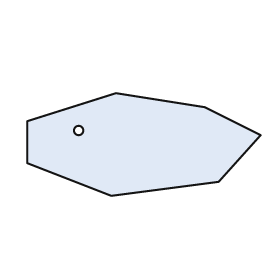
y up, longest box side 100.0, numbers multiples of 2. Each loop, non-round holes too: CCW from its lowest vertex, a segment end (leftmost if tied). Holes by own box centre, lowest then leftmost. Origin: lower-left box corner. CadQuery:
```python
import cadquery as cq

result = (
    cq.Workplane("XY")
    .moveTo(36.0, 0.0)
    .lineTo(82.0, 6.0)
    .lineTo(100.0, 26.0)
    .lineTo(76.0, 38.0)
    .lineTo(38.0, 44.0)
    .lineTo(0.0, 32.0)
    .lineTo(0.0, 14.0)
    .close()
    .moveTo(22.0, 28.0)
    .circle(2.0)
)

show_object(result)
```